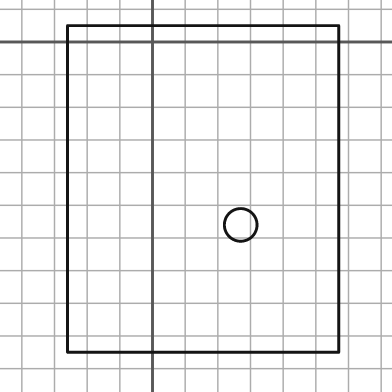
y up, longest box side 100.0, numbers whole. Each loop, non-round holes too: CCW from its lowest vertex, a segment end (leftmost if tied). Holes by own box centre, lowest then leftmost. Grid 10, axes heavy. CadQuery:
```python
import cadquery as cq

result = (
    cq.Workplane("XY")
    .moveTo(-26.0, -95.0)
    .lineTo(57.0, -95.0)
    .lineTo(57.0, 5.0)
    .lineTo(-26.0, 5.0)
    .close()
    .moveTo(27.0, -56.0)
    .circle(5.0)
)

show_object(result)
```